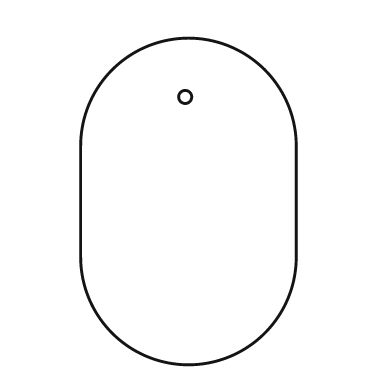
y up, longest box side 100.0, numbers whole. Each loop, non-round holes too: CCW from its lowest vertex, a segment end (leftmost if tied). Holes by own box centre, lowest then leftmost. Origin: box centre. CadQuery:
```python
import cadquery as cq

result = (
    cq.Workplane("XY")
    .moveTo(-33.0, -17.0)
    .threePointArc((0.0, -50.0), (33.0, -17.0))
    .lineTo(33.0, 17.0)
    .threePointArc((0.0, 50.0), (-33.0, 17.0))
    .close()
    .moveTo(-1.0, 32.0)
    .circle(2.0)
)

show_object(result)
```